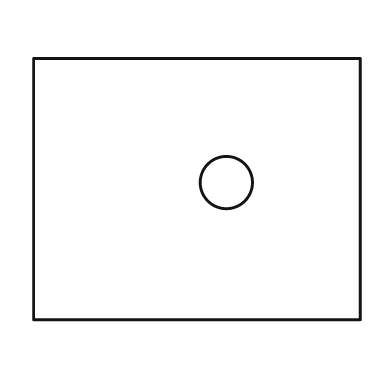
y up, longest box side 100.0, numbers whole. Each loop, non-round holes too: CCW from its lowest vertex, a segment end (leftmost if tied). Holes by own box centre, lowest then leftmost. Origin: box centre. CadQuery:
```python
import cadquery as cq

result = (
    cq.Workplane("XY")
    .moveTo(-50.0, -40.0)
    .lineTo(50.0, -40.0)
    .lineTo(50.0, 40.0)
    .lineTo(-50.0, 40.0)
    .close()
    .moveTo(9.0, 2.0)
    .circle(8.0)
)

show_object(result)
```